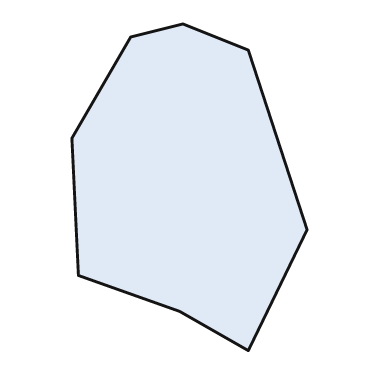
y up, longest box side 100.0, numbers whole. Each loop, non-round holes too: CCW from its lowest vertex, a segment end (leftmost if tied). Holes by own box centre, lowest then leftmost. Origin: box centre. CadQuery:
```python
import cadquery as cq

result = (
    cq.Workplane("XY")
    .moveTo(18.0, -50.0)
    .lineTo(36.0, -13.0)
    .lineTo(18.0, 42.0)
    .lineTo(-2.0, 50.0)
    .lineTo(-18.0, 46.0)
    .lineTo(-36.0, 15.0)
    .lineTo(-34.0, -27.0)
    .lineTo(-3.0, -38.0)
    .close()
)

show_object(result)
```